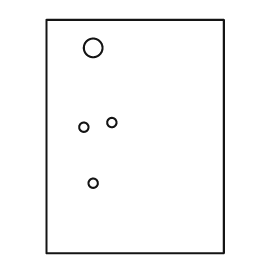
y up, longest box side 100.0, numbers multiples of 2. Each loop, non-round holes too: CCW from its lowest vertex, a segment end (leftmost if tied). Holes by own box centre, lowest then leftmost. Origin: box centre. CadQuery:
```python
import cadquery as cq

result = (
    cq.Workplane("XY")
    .moveTo(-38.0, -50.0)
    .lineTo(38.0, -50.0)
    .lineTo(38.0, 50.0)
    .lineTo(-38.0, 50.0)
    .close()
    .moveTo(-18.0, -20.0)
    .circle(2.0)
    .moveTo(-22.0, 4.0)
    .circle(2.0)
    .moveTo(-10.0, 6.0)
    .circle(2.0)
    .moveTo(-18.0, 38.0)
    .circle(4.0)
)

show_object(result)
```